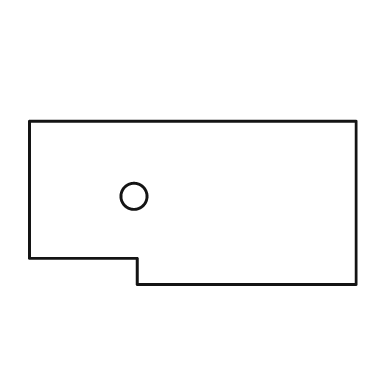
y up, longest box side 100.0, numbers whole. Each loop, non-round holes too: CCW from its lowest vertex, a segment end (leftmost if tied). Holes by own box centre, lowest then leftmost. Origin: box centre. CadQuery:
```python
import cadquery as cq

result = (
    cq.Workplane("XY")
    .moveTo(-17.0, -25.0)
    .lineTo(50.0, -25.0)
    .lineTo(50.0, 25.0)
    .lineTo(-50.0, 25.0)
    .lineTo(-50.0, -17.0)
    .lineTo(-17.0, -17.0)
    .close()
    .moveTo(-18.0, 2.0)
    .circle(4.0)
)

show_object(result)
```